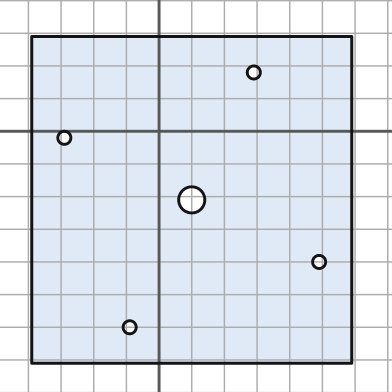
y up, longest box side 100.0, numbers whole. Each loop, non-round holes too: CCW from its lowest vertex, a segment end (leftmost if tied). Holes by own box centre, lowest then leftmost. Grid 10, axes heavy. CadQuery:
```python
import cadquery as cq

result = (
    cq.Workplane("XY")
    .moveTo(-39.0, -71.0)
    .lineTo(59.0, -71.0)
    .lineTo(59.0, 29.0)
    .lineTo(-39.0, 29.0)
    .close()
    .moveTo(-9.0, -60.0)
    .circle(2.0)
    .moveTo(49.0, -40.0)
    .circle(2.0)
    .moveTo(10.0, -21.0)
    .circle(4.0)
    .moveTo(-29.0, -2.0)
    .circle(2.0)
    .moveTo(29.0, 18.0)
    .circle(2.0)
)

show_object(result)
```